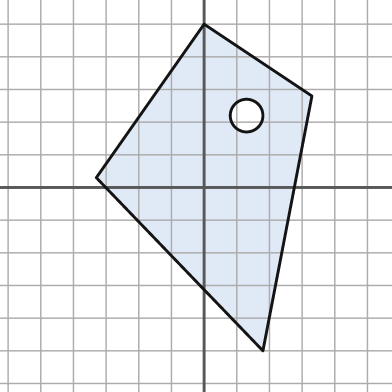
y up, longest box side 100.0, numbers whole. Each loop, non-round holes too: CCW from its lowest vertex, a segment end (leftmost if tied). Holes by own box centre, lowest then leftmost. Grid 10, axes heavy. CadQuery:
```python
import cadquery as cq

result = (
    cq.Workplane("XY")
    .moveTo(18.0, -50.0)
    .lineTo(33.0, 28.0)
    .lineTo(0.0, 50.0)
    .lineTo(-33.0, 3.0)
    .close()
    .moveTo(13.0, 22.0)
    .circle(5.0)
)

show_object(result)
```